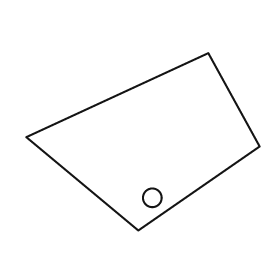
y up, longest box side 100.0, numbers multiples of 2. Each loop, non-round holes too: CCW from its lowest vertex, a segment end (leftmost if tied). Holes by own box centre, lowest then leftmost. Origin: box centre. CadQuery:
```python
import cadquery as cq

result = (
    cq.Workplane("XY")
    .moveTo(-2.0, -38.0)
    .lineTo(50.0, -2.0)
    .lineTo(28.0, 38.0)
    .lineTo(-50.0, 2.0)
    .close()
    .moveTo(4.0, -24.0)
    .circle(4.0)
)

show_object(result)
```